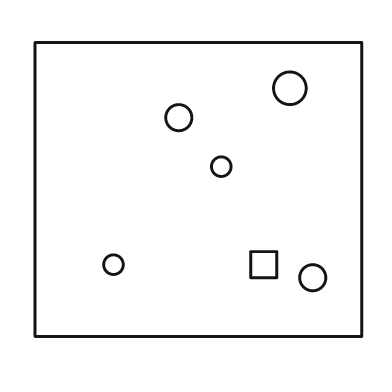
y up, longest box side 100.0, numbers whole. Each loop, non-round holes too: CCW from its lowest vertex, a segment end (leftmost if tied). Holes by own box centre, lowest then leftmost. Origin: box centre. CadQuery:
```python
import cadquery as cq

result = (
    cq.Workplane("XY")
    .moveTo(-50.0, -45.0)
    .lineTo(50.0, -45.0)
    .lineTo(50.0, 45.0)
    .lineTo(-50.0, 45.0)
    .close()
    .moveTo(35.0, -27.0)
    .circle(4.0)
    .moveTo(-26.0, -23.0)
    .circle(3.0)
    .moveTo(16.0, -27.0)
    .lineTo(24.0, -27.0)
    .lineTo(24.0, -19.0)
    .lineTo(16.0, -19.0)
    .close()
    .moveTo(7.0, 7.0)
    .circle(3.0)
    .moveTo(-6.0, 22.0)
    .circle(4.0)
    .moveTo(28.0, 31.0)
    .circle(5.0)
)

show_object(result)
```